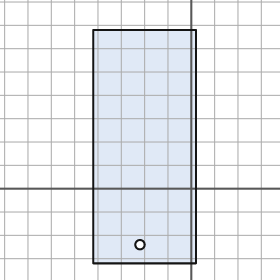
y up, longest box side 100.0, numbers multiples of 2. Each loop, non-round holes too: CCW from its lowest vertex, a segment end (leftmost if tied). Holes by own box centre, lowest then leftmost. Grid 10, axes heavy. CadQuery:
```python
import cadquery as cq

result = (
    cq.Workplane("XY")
    .moveTo(-42.0, -32.0)
    .lineTo(2.0, -32.0)
    .lineTo(2.0, 68.0)
    .lineTo(-42.0, 68.0)
    .close()
    .moveTo(-22.0, -24.0)
    .circle(2.0)
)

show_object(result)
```